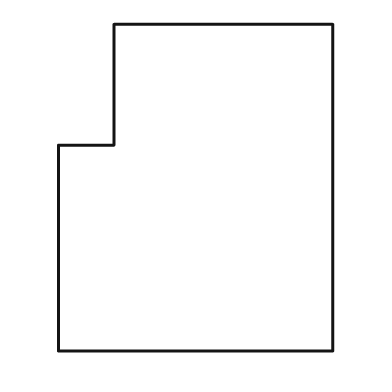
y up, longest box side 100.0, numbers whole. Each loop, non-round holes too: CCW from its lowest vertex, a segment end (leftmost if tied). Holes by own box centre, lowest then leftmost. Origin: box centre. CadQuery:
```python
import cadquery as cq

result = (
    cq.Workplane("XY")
    .moveTo(-42.0, -50.0)
    .lineTo(42.0, -50.0)
    .lineTo(42.0, 50.0)
    .lineTo(-25.0, 50.0)
    .lineTo(-25.0, 13.0)
    .lineTo(-42.0, 13.0)
    .close()
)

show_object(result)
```